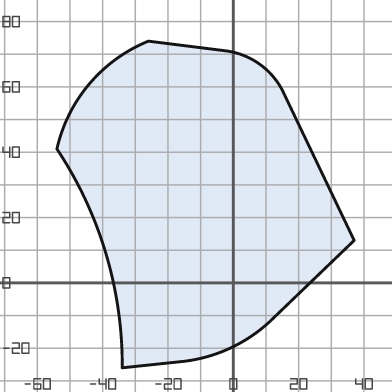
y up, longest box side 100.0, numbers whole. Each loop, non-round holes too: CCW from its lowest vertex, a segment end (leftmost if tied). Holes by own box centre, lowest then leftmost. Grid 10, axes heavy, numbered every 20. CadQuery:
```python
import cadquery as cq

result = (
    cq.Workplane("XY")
    .moveTo(-34.0, -26.0)
    .lineTo(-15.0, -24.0)
    .threePointArc((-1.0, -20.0), (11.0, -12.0))
    .lineTo(37.0, 13.0)
    .lineTo(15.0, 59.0)
    .threePointArc((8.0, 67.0), (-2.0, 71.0))
    .lineTo(-26.0, 74.0)
    .threePointArc((-44.0, 61.0), (-54.0, 41.0))
    .threePointArc((-39.0, 9.0), (-34.0, -26.0))
    .close()
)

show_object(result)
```